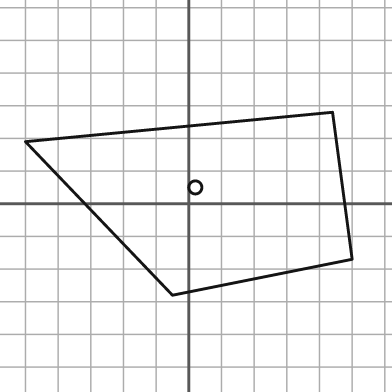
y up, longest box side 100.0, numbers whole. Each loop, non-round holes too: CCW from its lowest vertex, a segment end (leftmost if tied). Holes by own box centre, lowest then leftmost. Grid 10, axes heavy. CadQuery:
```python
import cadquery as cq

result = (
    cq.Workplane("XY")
    .moveTo(-5.0, -28.0)
    .lineTo(50.0, -17.0)
    .lineTo(44.0, 28.0)
    .lineTo(-50.0, 19.0)
    .close()
    .moveTo(2.0, 5.0)
    .circle(2.0)
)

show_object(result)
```